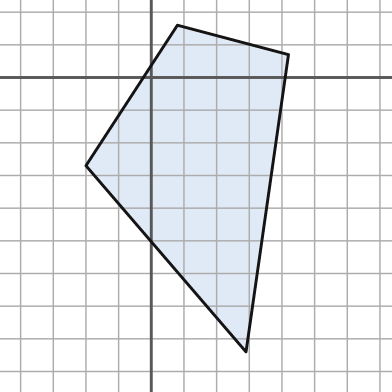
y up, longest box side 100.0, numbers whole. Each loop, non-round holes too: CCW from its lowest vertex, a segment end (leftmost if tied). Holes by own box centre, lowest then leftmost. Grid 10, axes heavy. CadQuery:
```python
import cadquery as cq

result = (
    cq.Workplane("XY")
    .moveTo(29.0, -84.0)
    .lineTo(42.0, 7.0)
    .lineTo(8.0, 16.0)
    .lineTo(-20.0, -27.0)
    .close()
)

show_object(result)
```